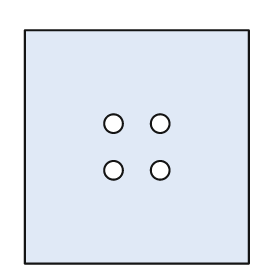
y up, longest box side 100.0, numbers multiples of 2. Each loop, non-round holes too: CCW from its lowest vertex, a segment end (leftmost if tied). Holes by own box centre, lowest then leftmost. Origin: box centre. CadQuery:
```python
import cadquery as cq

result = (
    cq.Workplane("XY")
    .moveTo(-48.0, -50.0)
    .lineTo(48.0, -50.0)
    .lineTo(48.0, 50.0)
    .lineTo(-48.0, 50.0)
    .close()
    .moveTo(-10.0, -10.0)
    .circle(4.0)
    .moveTo(10.0, -10.0)
    .circle(4.0)
    .moveTo(-10.0, 10.0)
    .circle(4.0)
    .moveTo(10.0, 10.0)
    .circle(4.0)
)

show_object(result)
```